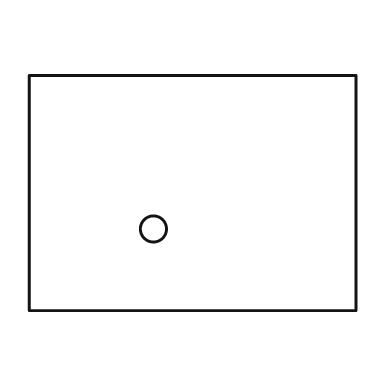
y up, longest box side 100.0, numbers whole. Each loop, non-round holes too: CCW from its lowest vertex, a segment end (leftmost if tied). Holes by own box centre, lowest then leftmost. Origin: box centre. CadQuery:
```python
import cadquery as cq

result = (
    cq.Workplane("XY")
    .moveTo(-50.0, -36.0)
    .lineTo(50.0, -36.0)
    .lineTo(50.0, 36.0)
    .lineTo(-50.0, 36.0)
    .close()
    .moveTo(-12.0, -11.0)
    .circle(4.0)
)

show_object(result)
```